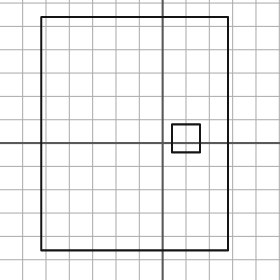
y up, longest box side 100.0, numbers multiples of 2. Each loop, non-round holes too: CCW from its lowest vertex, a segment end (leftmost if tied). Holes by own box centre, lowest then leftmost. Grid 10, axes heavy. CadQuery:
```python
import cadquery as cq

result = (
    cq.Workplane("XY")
    .moveTo(-52.0, -46.0)
    .lineTo(28.0, -46.0)
    .lineTo(28.0, 54.0)
    .lineTo(-52.0, 54.0)
    .close()
    .moveTo(4.0, -4.0)
    .lineTo(16.0, -4.0)
    .lineTo(16.0, 8.0)
    .lineTo(4.0, 8.0)
    .close()
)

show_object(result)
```